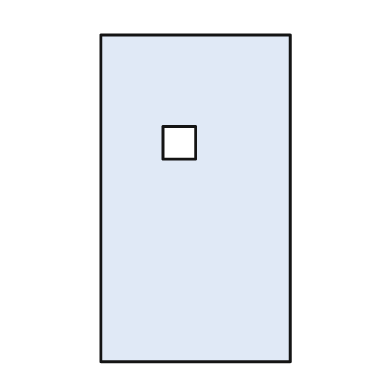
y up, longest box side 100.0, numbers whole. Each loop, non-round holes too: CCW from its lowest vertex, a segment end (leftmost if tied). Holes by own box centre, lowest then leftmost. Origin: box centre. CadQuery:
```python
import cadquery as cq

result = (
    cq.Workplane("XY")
    .moveTo(-29.0, -50.0)
    .lineTo(29.0, -50.0)
    .lineTo(29.0, 50.0)
    .lineTo(-29.0, 50.0)
    .close()
    .moveTo(-10.0, 12.0)
    .lineTo(0.0, 12.0)
    .lineTo(0.0, 22.0)
    .lineTo(-10.0, 22.0)
    .close()
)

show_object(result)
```